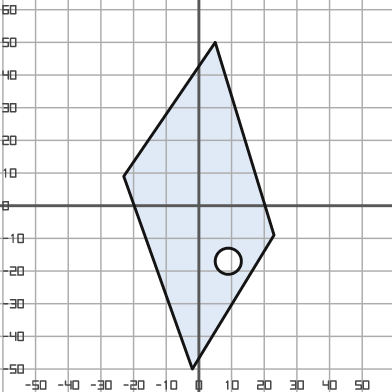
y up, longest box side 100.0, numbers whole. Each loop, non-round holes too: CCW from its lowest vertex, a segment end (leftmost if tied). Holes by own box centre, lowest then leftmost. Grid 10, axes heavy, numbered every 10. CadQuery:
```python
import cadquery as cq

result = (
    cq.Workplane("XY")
    .moveTo(-2.0, -50.0)
    .lineTo(23.0, -9.0)
    .lineTo(5.0, 50.0)
    .lineTo(-23.0, 9.0)
    .close()
    .moveTo(9.0, -17.0)
    .circle(4.0)
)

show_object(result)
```